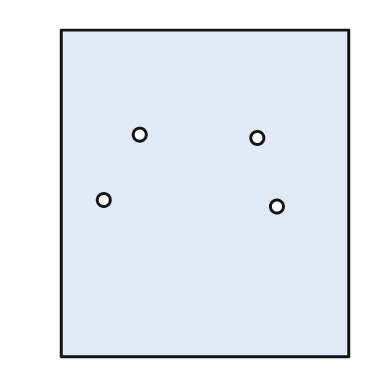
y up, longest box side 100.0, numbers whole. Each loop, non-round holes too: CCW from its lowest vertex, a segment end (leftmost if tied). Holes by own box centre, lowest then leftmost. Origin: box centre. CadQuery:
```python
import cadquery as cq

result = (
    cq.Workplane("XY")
    .moveTo(-44.0, -50.0)
    .lineTo(44.0, -50.0)
    .lineTo(44.0, 50.0)
    .lineTo(-44.0, 50.0)
    .close()
    .moveTo(22.0, -4.0)
    .circle(2.0)
    .moveTo(-31.0, -2.0)
    .circle(2.0)
    .moveTo(16.0, 17.0)
    .circle(2.0)
    .moveTo(-20.0, 18.0)
    .circle(2.0)
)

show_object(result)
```